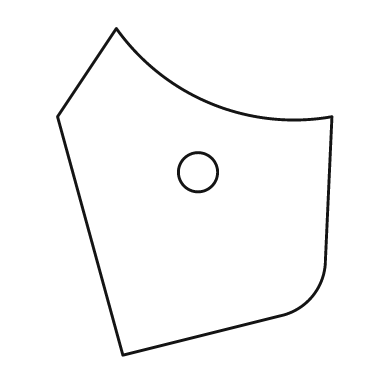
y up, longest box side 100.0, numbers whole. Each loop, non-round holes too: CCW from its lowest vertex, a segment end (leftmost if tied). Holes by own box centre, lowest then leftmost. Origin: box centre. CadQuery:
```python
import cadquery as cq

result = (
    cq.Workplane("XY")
    .moveTo(-22.0, -50.0)
    .lineTo(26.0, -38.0)
    .threePointArc((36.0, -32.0), (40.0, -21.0))
    .lineTo(42.0, 23.0)
    .threePointArc((5.0, 27.0), (-24.0, 50.0))
    .lineTo(-42.0, 23.0)
    .close()
    .moveTo(1.0, 6.0)
    .circle(6.0)
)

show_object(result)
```